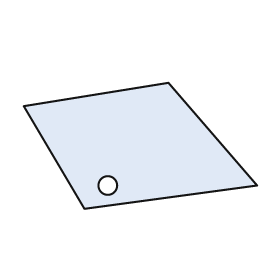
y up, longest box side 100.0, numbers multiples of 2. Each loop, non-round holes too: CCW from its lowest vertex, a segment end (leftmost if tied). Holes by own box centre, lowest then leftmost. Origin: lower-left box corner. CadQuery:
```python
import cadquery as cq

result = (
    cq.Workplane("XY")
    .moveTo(26.0, 0.0)
    .lineTo(100.0, 10.0)
    .lineTo(62.0, 54.0)
    .lineTo(0.0, 44.0)
    .close()
    .moveTo(36.0, 10.0)
    .circle(4.0)
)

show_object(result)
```